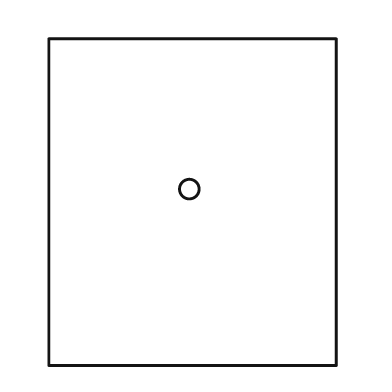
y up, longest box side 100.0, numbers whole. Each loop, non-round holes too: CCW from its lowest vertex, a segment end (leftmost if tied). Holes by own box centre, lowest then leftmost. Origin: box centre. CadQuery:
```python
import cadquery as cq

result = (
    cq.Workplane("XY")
    .moveTo(-44.0, -50.0)
    .lineTo(44.0, -50.0)
    .lineTo(44.0, 50.0)
    .lineTo(-44.0, 50.0)
    .close()
    .moveTo(-1.0, 4.0)
    .circle(3.0)
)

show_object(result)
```